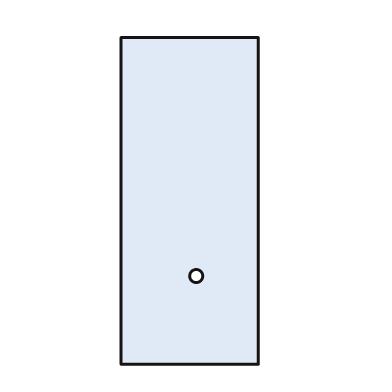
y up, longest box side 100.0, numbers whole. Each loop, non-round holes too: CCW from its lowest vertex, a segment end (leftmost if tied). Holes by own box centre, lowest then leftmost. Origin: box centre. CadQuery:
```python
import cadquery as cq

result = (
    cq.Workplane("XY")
    .moveTo(-21.0, -50.0)
    .lineTo(21.0, -50.0)
    .lineTo(21.0, 50.0)
    .lineTo(-21.0, 50.0)
    .close()
    .moveTo(2.0, -23.0)
    .circle(2.0)
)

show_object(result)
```